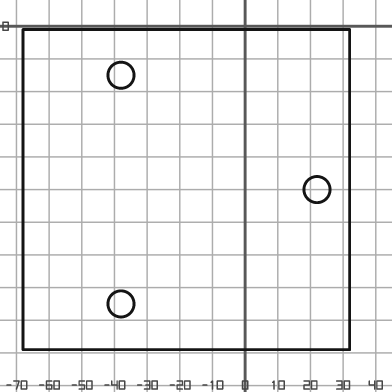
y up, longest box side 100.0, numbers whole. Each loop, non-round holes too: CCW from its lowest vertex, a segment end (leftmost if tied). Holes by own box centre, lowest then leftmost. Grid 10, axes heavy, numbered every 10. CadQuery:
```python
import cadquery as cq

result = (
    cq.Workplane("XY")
    .moveTo(-68.0, -99.0)
    .lineTo(32.0, -99.0)
    .lineTo(32.0, -1.0)
    .lineTo(-68.0, -1.0)
    .close()
    .moveTo(-38.0, -85.0)
    .circle(4.0)
    .moveTo(22.0, -50.0)
    .circle(4.0)
    .moveTo(-38.0, -15.0)
    .circle(4.0)
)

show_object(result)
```